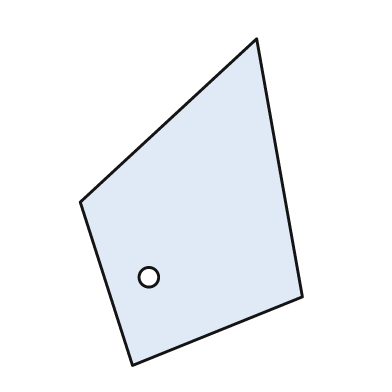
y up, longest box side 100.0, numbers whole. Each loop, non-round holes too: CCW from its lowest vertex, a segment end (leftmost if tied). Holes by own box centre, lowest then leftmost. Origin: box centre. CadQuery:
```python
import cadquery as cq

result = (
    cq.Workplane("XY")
    .moveTo(-18.0, -50.0)
    .lineTo(34.0, -29.0)
    .lineTo(20.0, 50.0)
    .lineTo(-34.0, 0.0)
    .close()
    .moveTo(-13.0, -23.0)
    .circle(3.0)
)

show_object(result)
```